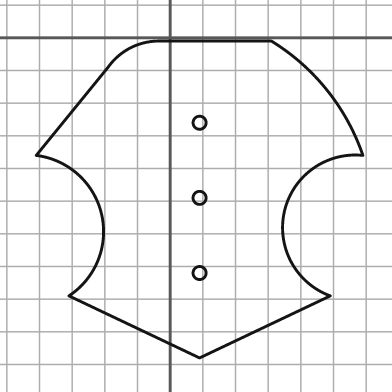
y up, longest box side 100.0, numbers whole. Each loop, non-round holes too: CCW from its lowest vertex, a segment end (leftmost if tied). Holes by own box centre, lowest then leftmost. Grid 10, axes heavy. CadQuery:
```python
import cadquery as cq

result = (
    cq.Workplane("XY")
    .moveTo(9.0, -98.0)
    .lineTo(49.0, -79.0)
    .threePointArc((35.0, -53.0), (59.0, -36.0))
    .threePointArc((48.0, -16.0), (31.0, -1.0))
    .lineTo(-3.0, -1.0)
    .threePointArc((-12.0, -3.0), (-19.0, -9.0))
    .lineTo(-41.0, -36.0)
    .threePointArc((-21.0, -54.0), (-31.0, -79.0))
    .close()
    .moveTo(9.0, -72.0)
    .circle(2.0)
    .moveTo(9.0, -49.0)
    .circle(2.0)
    .moveTo(9.0, -26.0)
    .circle(2.0)
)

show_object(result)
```